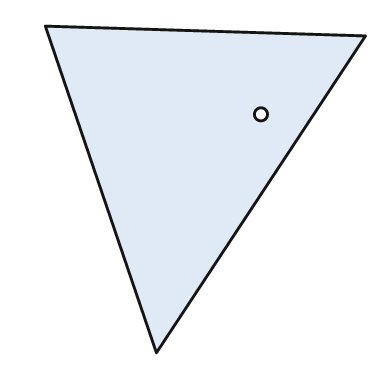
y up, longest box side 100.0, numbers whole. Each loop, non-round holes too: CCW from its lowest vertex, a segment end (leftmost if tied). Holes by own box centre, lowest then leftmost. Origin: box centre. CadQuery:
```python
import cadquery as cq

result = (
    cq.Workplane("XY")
    .moveTo(-15.0, -50.0)
    .lineTo(49.0, 47.0)
    .lineTo(-49.0, 50.0)
    .close()
    .moveTo(17.0, 23.0)
    .circle(2.0)
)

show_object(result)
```